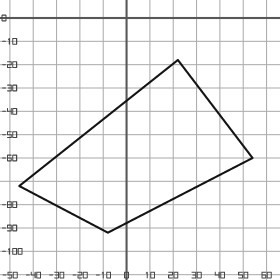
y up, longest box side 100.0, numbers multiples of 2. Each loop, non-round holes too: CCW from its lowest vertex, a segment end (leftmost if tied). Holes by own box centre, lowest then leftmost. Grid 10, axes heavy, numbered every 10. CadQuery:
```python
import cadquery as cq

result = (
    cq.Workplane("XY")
    .moveTo(-8.0, -92.0)
    .lineTo(54.0, -60.0)
    .lineTo(22.0, -18.0)
    .lineTo(-46.0, -72.0)
    .close()
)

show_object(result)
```